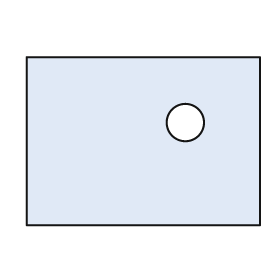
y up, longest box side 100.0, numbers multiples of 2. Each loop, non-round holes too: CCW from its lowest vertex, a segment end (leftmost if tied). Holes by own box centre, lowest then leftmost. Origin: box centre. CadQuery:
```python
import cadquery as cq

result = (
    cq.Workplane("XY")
    .moveTo(-50.0, -36.0)
    .lineTo(50.0, -36.0)
    .lineTo(50.0, 36.0)
    .lineTo(-50.0, 36.0)
    .close()
    .moveTo(18.0, 8.0)
    .circle(8.0)
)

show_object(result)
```